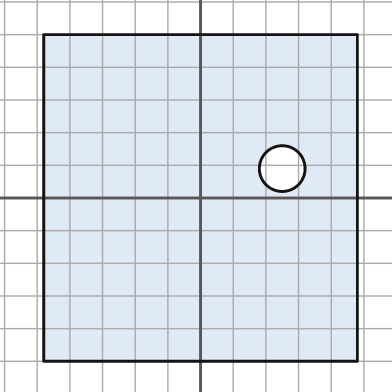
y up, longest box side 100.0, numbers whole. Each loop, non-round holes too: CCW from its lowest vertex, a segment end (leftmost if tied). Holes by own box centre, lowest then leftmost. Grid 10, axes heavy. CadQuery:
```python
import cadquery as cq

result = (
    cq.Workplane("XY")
    .moveTo(-48.0, -50.0)
    .lineTo(48.0, -50.0)
    .lineTo(48.0, 50.0)
    .lineTo(-48.0, 50.0)
    .close()
    .moveTo(25.0, 9.0)
    .circle(7.0)
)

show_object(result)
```